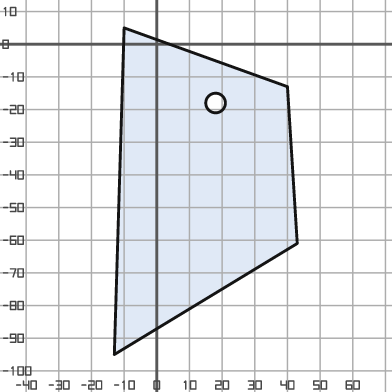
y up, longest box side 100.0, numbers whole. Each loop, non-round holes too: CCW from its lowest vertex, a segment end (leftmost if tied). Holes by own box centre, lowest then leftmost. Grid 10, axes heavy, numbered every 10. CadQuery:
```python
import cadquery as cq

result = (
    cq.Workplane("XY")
    .moveTo(-13.0, -95.0)
    .lineTo(43.0, -61.0)
    .lineTo(40.0, -13.0)
    .lineTo(-10.0, 5.0)
    .close()
    .moveTo(18.0, -18.0)
    .circle(3.0)
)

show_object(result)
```